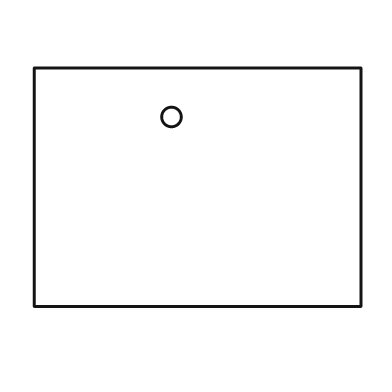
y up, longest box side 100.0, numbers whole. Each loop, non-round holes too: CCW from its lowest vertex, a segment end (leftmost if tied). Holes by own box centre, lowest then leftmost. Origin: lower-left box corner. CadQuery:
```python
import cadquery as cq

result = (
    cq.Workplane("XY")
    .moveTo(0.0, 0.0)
    .lineTo(100.0, 0.0)
    .lineTo(100.0, 73.0)
    .lineTo(0.0, 73.0)
    .close()
    .moveTo(42.0, 58.0)
    .circle(3.0)
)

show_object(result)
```